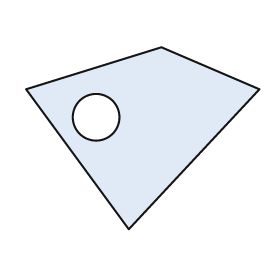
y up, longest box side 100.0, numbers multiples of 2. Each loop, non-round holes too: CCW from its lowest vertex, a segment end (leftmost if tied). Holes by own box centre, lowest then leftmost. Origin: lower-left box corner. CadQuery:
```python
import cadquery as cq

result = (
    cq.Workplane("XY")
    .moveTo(44.0, 0.0)
    .lineTo(100.0, 60.0)
    .lineTo(58.0, 78.0)
    .lineTo(0.0, 60.0)
    .close()
    .moveTo(30.0, 48.0)
    .circle(10.0)
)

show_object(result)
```